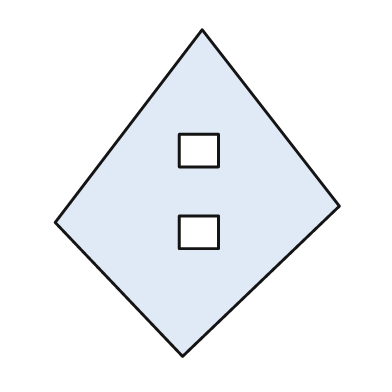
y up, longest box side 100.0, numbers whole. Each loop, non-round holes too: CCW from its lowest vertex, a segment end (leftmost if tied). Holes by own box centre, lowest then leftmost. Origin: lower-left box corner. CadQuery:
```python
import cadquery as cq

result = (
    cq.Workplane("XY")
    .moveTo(39.0, 0.0)
    .lineTo(87.0, 46.0)
    .lineTo(45.0, 100.0)
    .lineTo(0.0, 41.0)
    .close()
    .moveTo(38.0, 33.0)
    .lineTo(50.0, 33.0)
    .lineTo(50.0, 43.0)
    .lineTo(38.0, 43.0)
    .close()
    .moveTo(38.0, 58.0)
    .lineTo(50.0, 58.0)
    .lineTo(50.0, 68.0)
    .lineTo(38.0, 68.0)
    .close()
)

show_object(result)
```